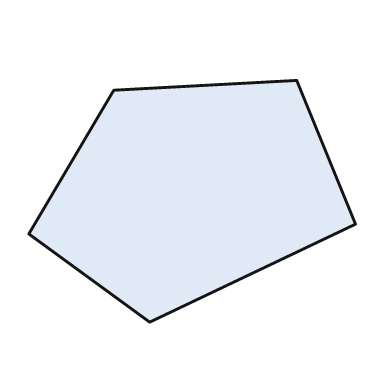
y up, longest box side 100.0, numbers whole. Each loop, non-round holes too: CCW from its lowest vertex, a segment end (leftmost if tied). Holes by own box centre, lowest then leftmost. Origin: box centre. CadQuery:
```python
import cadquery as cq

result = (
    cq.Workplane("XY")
    .moveTo(-13.0, -37.0)
    .lineTo(50.0, -7.0)
    .lineTo(32.0, 37.0)
    .lineTo(-24.0, 34.0)
    .lineTo(-50.0, -10.0)
    .close()
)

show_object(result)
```